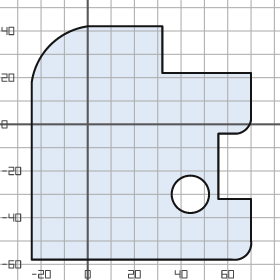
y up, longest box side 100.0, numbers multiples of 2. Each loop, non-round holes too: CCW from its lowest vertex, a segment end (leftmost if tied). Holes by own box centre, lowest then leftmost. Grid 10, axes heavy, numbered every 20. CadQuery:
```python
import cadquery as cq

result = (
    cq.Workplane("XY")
    .moveTo(-24.0, -58.0)
    .lineTo(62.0, -58.0)
    .threePointArc((68.0, -56.0), (70.0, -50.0))
    .lineTo(70.0, -32.0)
    .lineTo(56.0, -32.0)
    .lineTo(56.0, -4.0)
    .lineTo(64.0, -4.0)
    .threePointArc((68.0, -2.0), (70.0, 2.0))
    .lineTo(70.0, 22.0)
    .lineTo(32.0, 22.0)
    .lineTo(32.0, 42.0)
    .lineTo(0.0, 42.0)
    .threePointArc((-16.0, 34.0), (-24.0, 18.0))
    .close()
    .moveTo(44.0, -30.0)
    .circle(8.0)
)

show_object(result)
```